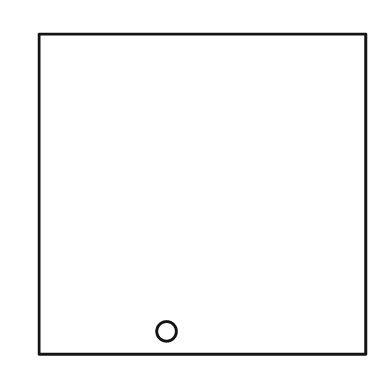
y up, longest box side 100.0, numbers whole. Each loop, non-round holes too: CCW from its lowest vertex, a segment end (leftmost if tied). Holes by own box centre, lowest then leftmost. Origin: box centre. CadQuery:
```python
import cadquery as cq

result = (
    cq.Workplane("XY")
    .moveTo(-50.0, -49.0)
    .lineTo(50.0, -49.0)
    .lineTo(50.0, 49.0)
    .lineTo(-50.0, 49.0)
    .close()
    .moveTo(-11.0, -42.0)
    .circle(3.0)
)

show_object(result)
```